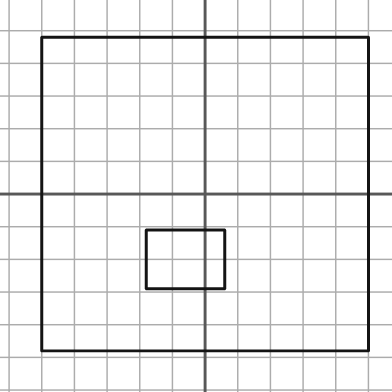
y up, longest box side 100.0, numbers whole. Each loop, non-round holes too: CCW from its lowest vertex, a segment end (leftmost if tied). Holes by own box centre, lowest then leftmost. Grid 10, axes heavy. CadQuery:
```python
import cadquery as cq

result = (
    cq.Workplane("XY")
    .moveTo(-50.0, -48.0)
    .lineTo(50.0, -48.0)
    .lineTo(50.0, 48.0)
    .lineTo(-50.0, 48.0)
    .close()
    .moveTo(-18.0, -29.0)
    .lineTo(6.0, -29.0)
    .lineTo(6.0, -11.0)
    .lineTo(-18.0, -11.0)
    .close()
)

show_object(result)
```